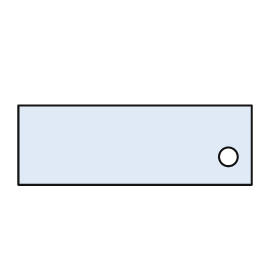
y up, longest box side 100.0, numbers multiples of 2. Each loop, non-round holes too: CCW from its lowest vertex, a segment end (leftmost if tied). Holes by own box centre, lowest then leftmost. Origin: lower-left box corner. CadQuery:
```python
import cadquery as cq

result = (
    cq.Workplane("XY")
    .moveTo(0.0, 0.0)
    .lineTo(100.0, 0.0)
    .lineTo(100.0, 34.0)
    .lineTo(0.0, 34.0)
    .close()
    .moveTo(90.0, 12.0)
    .circle(4.0)
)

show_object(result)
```